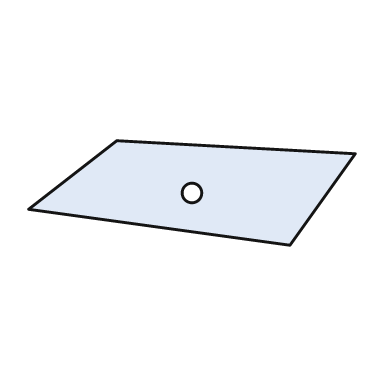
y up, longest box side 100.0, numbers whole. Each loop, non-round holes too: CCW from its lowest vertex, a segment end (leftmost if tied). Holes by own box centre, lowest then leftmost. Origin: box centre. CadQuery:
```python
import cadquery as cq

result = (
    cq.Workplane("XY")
    .moveTo(30.0, -16.0)
    .lineTo(50.0, 12.0)
    .lineTo(-23.0, 16.0)
    .lineTo(-50.0, -5.0)
    .close()
    .moveTo(0.0, 0.0)
    .circle(3.0)
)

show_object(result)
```